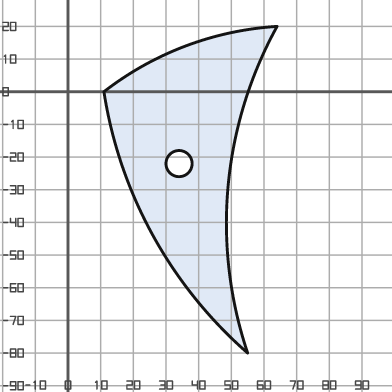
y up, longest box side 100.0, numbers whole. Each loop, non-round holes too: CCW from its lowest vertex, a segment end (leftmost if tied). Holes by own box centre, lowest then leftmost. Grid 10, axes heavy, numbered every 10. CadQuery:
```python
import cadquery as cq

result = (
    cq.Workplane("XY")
    .moveTo(55.0, -80.0)
    .threePointArc((49.0, -29.0), (64.0, 20.0))
    .threePointArc((36.0, 14.0), (11.0, 0.0))
    .threePointArc((26.0, -44.0), (55.0, -80.0))
    .close()
    .moveTo(34.0, -22.0)
    .circle(4.0)
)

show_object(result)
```